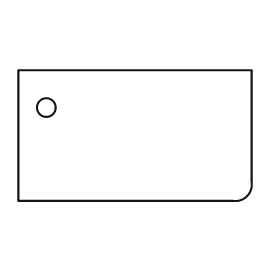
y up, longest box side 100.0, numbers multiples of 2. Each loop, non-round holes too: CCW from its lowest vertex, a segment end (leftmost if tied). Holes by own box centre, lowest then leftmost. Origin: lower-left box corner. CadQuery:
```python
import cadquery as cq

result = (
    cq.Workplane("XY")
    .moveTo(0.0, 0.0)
    .lineTo(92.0, 0.0)
    .threePointArc((98.0, 2.0), (100.0, 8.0))
    .lineTo(100.0, 56.0)
    .lineTo(0.0, 56.0)
    .close()
    .moveTo(12.0, 40.0)
    .circle(4.0)
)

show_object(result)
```